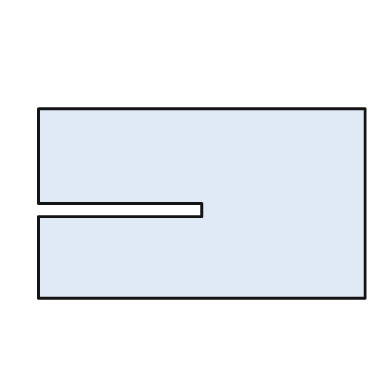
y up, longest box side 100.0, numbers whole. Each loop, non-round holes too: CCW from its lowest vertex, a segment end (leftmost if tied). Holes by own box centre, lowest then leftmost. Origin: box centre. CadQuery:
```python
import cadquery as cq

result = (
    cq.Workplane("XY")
    .moveTo(-50.0, -29.0)
    .lineTo(50.0, -29.0)
    .lineTo(50.0, 29.0)
    .lineTo(-50.0, 29.0)
    .lineTo(-50.0, 0.0)
    .lineTo(0.0, 0.0)
    .lineTo(0.0, -4.0)
    .lineTo(-50.0, -4.0)
    .close()
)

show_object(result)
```